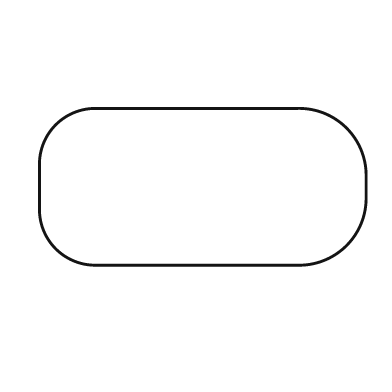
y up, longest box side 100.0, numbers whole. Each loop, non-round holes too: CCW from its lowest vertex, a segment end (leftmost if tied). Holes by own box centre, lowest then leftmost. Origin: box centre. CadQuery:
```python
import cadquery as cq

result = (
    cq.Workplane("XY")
    .moveTo(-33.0, -24.0)
    .lineTo(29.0, -24.0)
    .threePointArc((44.0, -18.0), (50.0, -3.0))
    .lineTo(50.0, 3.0)
    .threePointArc((44.0, 18.0), (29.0, 24.0))
    .lineTo(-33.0, 24.0)
    .threePointArc((-45.0, 19.0), (-50.0, 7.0))
    .lineTo(-50.0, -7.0)
    .threePointArc((-45.0, -19.0), (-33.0, -24.0))
    .close()
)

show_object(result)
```